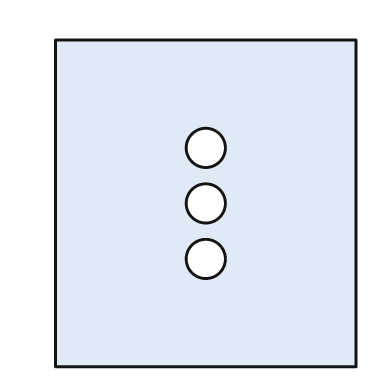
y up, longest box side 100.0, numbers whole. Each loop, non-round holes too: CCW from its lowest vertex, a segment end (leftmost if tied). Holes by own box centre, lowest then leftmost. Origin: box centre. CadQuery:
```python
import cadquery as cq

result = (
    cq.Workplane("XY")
    .moveTo(-46.0, -50.0)
    .lineTo(46.0, -50.0)
    .lineTo(46.0, 50.0)
    .lineTo(-46.0, 50.0)
    .close()
    .moveTo(0.0, -17.0)
    .circle(6.0)
    .moveTo(0.0, 0.0)
    .circle(6.0)
    .moveTo(0.0, 17.0)
    .circle(6.0)
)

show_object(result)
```